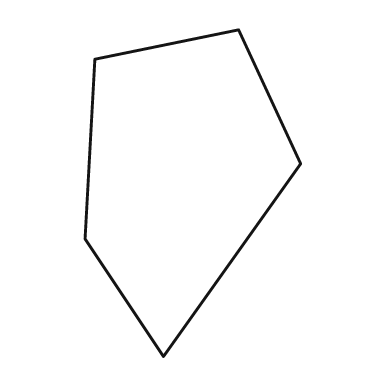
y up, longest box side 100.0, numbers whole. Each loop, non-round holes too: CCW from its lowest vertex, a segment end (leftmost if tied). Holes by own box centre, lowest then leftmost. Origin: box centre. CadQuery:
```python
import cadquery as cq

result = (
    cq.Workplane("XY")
    .moveTo(-9.0, -50.0)
    .lineTo(33.0, 9.0)
    .lineTo(14.0, 50.0)
    .lineTo(-30.0, 41.0)
    .lineTo(-33.0, -14.0)
    .close()
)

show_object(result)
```